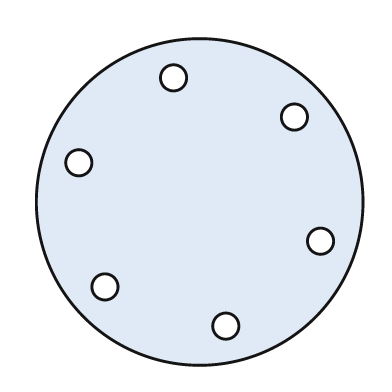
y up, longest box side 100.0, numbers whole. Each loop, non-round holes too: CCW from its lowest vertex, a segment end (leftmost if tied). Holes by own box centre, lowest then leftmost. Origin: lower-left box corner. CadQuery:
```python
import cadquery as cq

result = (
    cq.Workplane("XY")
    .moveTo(50.0, 50.0)
    .circle(50.0)
    .moveTo(58.0, 12.0)
    .circle(4.0)
    .moveTo(21.0, 24.0)
    .circle(4.0)
    .moveTo(87.0, 38.0)
    .circle(4.0)
    .moveTo(13.0, 62.0)
    .circle(4.0)
    .moveTo(79.0, 76.0)
    .circle(4.0)
    .moveTo(42.0, 88.0)
    .circle(4.0)
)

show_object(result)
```